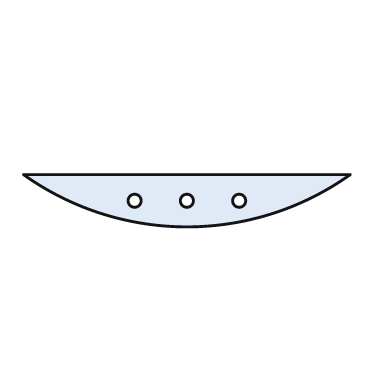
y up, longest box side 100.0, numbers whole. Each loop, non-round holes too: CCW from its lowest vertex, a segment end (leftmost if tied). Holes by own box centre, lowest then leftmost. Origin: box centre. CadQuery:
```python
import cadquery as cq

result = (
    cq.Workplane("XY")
    .moveTo(-50.0, 8.0)
    .threePointArc((0.0, -8.0), (50.0, 8.0))
    .close()
    .moveTo(-16.0, 0.0)
    .circle(2.0)
    .moveTo(0.0, 0.0)
    .circle(2.0)
    .moveTo(16.0, 0.0)
    .circle(2.0)
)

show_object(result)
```